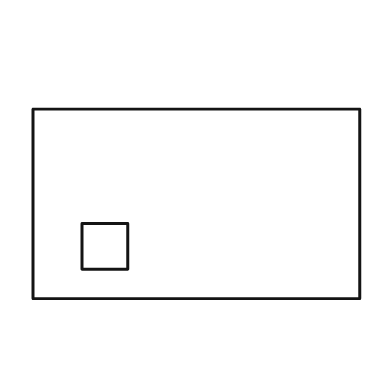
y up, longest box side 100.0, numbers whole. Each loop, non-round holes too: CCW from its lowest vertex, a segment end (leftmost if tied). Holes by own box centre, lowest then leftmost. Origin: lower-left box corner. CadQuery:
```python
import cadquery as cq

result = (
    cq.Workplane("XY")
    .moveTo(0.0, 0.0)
    .lineTo(100.0, 0.0)
    .lineTo(100.0, 58.0)
    .lineTo(0.0, 58.0)
    .close()
    .moveTo(15.0, 9.0)
    .lineTo(29.0, 9.0)
    .lineTo(29.0, 23.0)
    .lineTo(15.0, 23.0)
    .close()
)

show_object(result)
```